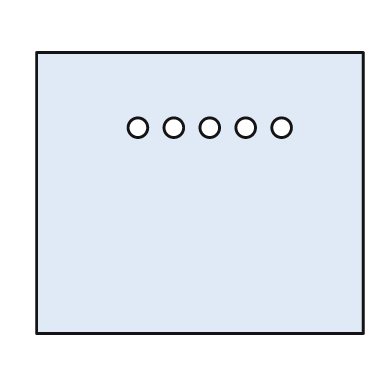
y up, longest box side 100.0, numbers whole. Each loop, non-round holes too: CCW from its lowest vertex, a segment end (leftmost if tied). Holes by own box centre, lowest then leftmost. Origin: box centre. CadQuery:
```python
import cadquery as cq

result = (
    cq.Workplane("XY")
    .moveTo(-50.0, -43.0)
    .lineTo(50.0, -43.0)
    .lineTo(50.0, 43.0)
    .lineTo(-50.0, 43.0)
    .close()
    .moveTo(-19.0, 20.0)
    .circle(3.0)
    .moveTo(-8.0, 20.0)
    .circle(3.0)
    .moveTo(3.0, 20.0)
    .circle(3.0)
    .moveTo(14.0, 20.0)
    .circle(3.0)
    .moveTo(25.0, 20.0)
    .circle(3.0)
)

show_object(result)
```